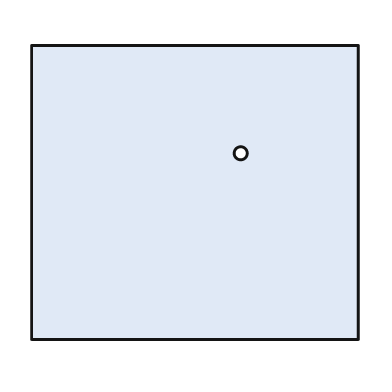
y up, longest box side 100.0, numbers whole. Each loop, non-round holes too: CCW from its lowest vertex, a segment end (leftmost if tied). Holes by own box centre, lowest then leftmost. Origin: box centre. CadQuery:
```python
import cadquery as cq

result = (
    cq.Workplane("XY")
    .moveTo(-50.0, -45.0)
    .lineTo(50.0, -45.0)
    .lineTo(50.0, 45.0)
    .lineTo(-50.0, 45.0)
    .close()
    .moveTo(14.0, 12.0)
    .circle(2.0)
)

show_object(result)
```